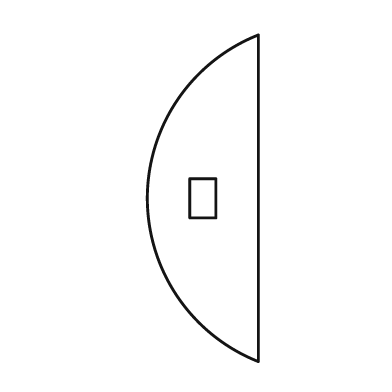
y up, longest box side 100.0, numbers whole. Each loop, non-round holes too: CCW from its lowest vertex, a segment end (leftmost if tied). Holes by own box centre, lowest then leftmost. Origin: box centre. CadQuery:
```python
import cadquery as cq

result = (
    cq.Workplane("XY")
    .moveTo(17.0, -50.0)
    .lineTo(17.0, 50.0)
    .threePointArc((-17.0, 0.0), (17.0, -50.0))
    .close()
    .moveTo(-4.0, -6.0)
    .lineTo(4.0, -6.0)
    .lineTo(4.0, 6.0)
    .lineTo(-4.0, 6.0)
    .close()
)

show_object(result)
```